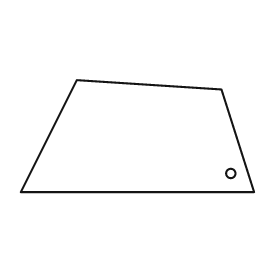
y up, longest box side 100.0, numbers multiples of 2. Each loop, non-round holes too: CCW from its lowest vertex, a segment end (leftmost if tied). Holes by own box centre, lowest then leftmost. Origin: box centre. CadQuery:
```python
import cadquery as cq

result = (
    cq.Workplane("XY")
    .moveTo(-50.0, -24.0)
    .lineTo(50.0, -24.0)
    .lineTo(36.0, 20.0)
    .lineTo(-26.0, 24.0)
    .close()
    .moveTo(40.0, -16.0)
    .circle(2.0)
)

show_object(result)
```